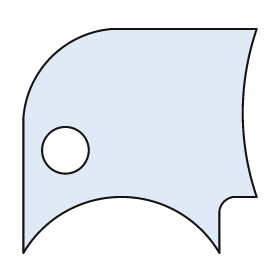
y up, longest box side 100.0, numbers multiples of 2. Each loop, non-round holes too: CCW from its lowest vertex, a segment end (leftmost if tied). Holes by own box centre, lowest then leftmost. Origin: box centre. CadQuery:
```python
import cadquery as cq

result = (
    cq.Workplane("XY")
    .moveTo(-50.0, -48.0)
    .threePointArc((-8.0, -24.0), (34.0, -48.0))
    .lineTo(34.0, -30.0)
    .threePointArc((36.0, -26.0), (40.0, -24.0))
    .lineTo(50.0, -24.0)
    .threePointArc((44.0, 12.0), (50.0, 48.0))
    .lineTo(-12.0, 48.0)
    .threePointArc((-38.0, 36.0), (-50.0, 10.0))
    .close()
    .moveTo(-32.0, -4.0)
    .circle(10.0)
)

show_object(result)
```